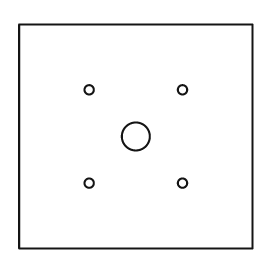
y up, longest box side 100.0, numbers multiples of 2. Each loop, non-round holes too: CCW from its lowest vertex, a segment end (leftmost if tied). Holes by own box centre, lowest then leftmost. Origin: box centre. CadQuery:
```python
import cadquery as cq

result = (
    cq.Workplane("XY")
    .moveTo(-50.0, -48.0)
    .lineTo(50.0, -48.0)
    .lineTo(50.0, 48.0)
    .lineTo(-50.0, 48.0)
    .close()
    .moveTo(-20.0, -20.0)
    .circle(2.0)
    .moveTo(20.0, -20.0)
    .circle(2.0)
    .moveTo(0.0, 0.0)
    .circle(6.0)
    .moveTo(-20.0, 20.0)
    .circle(2.0)
    .moveTo(20.0, 20.0)
    .circle(2.0)
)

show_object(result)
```